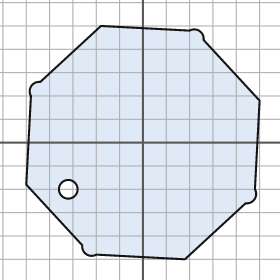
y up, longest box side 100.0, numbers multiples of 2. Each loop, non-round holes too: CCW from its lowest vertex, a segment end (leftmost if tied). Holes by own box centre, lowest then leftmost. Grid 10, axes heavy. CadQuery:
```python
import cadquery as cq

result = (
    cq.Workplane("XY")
    .moveTo(18.0, -50.0)
    .lineTo(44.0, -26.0)
    .threePointArc((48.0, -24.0), (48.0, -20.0))
    .lineTo(50.0, 18.0)
    .lineTo(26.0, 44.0)
    .threePointArc((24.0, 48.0), (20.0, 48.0))
    .lineTo(-18.0, 50.0)
    .lineTo(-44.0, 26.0)
    .threePointArc((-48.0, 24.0), (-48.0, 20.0))
    .lineTo(-50.0, -18.0)
    .lineTo(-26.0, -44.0)
    .threePointArc((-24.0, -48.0), (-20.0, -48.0))
    .close()
    .moveTo(-32.0, -20.0)
    .circle(4.0)
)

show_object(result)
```